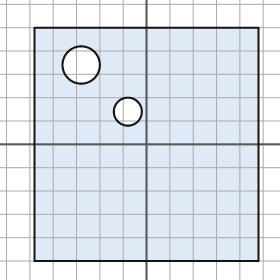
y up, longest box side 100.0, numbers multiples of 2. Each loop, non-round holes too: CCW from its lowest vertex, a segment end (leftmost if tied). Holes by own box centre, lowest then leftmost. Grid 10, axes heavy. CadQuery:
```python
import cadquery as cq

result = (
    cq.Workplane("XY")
    .moveTo(-48.0, -50.0)
    .lineTo(48.0, -50.0)
    .lineTo(48.0, 50.0)
    .lineTo(-48.0, 50.0)
    .close()
    .moveTo(-8.0, 14.0)
    .circle(6.0)
    .moveTo(-28.0, 34.0)
    .circle(8.0)
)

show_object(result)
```